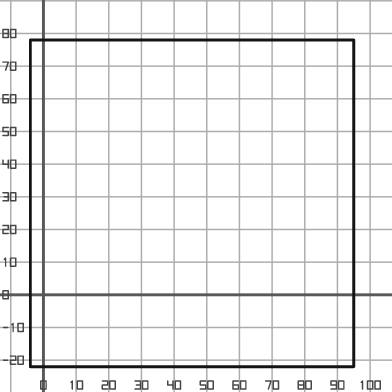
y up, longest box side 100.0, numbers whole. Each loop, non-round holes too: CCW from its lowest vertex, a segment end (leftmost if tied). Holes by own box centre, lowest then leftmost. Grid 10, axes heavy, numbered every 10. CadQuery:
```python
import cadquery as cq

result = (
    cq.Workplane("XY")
    .moveTo(-4.0, -22.0)
    .lineTo(95.0, -22.0)
    .lineTo(95.0, 78.0)
    .lineTo(-4.0, 78.0)
    .close()
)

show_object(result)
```